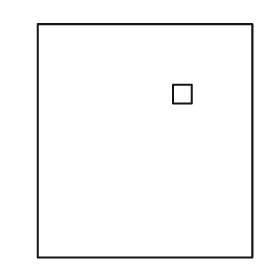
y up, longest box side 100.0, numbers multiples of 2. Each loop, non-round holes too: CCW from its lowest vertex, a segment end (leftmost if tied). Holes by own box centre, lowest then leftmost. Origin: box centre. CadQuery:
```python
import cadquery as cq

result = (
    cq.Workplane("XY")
    .moveTo(-46.0, -50.0)
    .lineTo(46.0, -50.0)
    .lineTo(46.0, 50.0)
    .lineTo(-46.0, 50.0)
    .close()
    .moveTo(12.0, 16.0)
    .lineTo(20.0, 16.0)
    .lineTo(20.0, 24.0)
    .lineTo(12.0, 24.0)
    .close()
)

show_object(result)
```